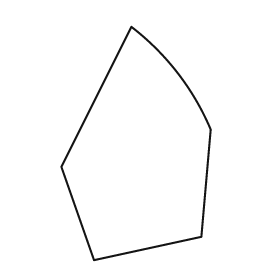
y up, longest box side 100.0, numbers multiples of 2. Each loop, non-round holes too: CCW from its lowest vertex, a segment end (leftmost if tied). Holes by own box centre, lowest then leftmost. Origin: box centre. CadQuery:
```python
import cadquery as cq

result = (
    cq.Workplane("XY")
    .moveTo(-18.0, -50.0)
    .lineTo(28.0, -40.0)
    .lineTo(32.0, 6.0)
    .threePointArc((18.0, 30.0), (-2.0, 50.0))
    .lineTo(-32.0, -10.0)
    .close()
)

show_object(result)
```